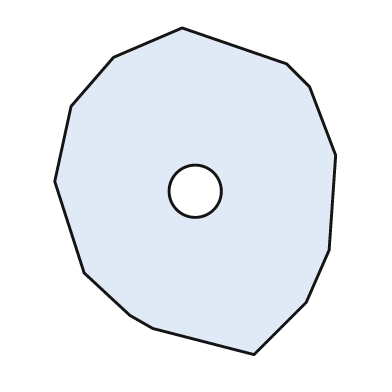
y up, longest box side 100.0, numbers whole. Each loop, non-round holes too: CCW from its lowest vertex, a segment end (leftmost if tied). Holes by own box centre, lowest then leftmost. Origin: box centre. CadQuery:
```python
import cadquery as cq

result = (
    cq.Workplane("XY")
    .moveTo(18.0, -50.0)
    .lineTo(34.0, -34.0)
    .lineTo(41.0, -18.0)
    .lineTo(43.0, 11.0)
    .lineTo(35.0, 32.0)
    .lineTo(28.0, 39.0)
    .lineTo(-4.0, 50.0)
    .lineTo(-25.0, 41.0)
    .lineTo(-38.0, 26.0)
    .lineTo(-43.0, 3.0)
    .lineTo(-34.0, -25.0)
    .lineTo(-20.0, -38.0)
    .lineTo(-13.0, -42.0)
    .close()
    .moveTo(0.0, 0.0)
    .circle(8.0)
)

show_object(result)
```